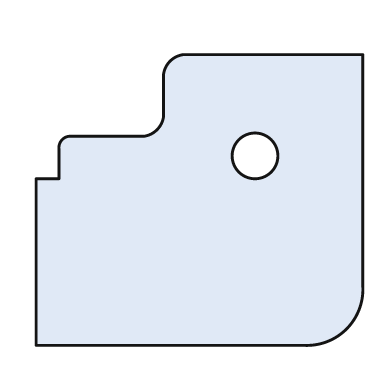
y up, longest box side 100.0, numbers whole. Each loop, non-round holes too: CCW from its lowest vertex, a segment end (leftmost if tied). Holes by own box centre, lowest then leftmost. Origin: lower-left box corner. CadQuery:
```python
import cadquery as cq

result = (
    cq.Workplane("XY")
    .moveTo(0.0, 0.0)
    .lineTo(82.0, 0.0)
    .threePointArc((95.0, 5.0), (100.0, 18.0))
    .lineTo(100.0, 89.0)
    .lineTo(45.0, 89.0)
    .threePointArc((41.0, 87.0), (39.0, 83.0))
    .lineTo(39.0, 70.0)
    .threePointArc((37.0, 66.0), (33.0, 64.0))
    .lineTo(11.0, 64.0)
    .threePointArc((8.0, 63.0), (7.0, 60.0))
    .lineTo(7.0, 51.0)
    .lineTo(0.0, 51.0)
    .close()
    .moveTo(67.0, 58.0)
    .circle(7.0)
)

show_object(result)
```